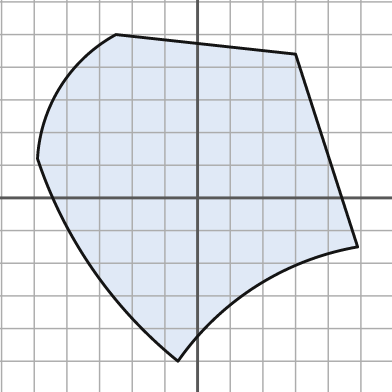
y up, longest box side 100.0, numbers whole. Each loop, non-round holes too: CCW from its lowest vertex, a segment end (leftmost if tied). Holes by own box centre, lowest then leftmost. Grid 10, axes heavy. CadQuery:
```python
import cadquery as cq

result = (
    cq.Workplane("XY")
    .moveTo(-6.0, -50.0)
    .threePointArc((18.0, -27.0), (49.0, -15.0))
    .lineTo(30.0, 44.0)
    .lineTo(-25.0, 50.0)
    .threePointArc((-42.0, 34.0), (-49.0, 12.0))
    .threePointArc((-32.0, -22.0), (-6.0, -50.0))
    .close()
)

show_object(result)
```